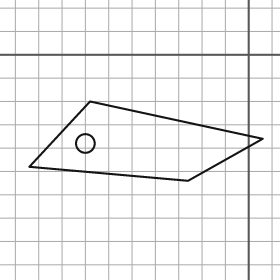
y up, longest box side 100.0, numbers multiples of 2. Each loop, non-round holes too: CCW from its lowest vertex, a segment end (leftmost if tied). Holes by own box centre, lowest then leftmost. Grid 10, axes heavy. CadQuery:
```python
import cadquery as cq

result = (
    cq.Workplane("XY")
    .moveTo(-26.0, -54.0)
    .lineTo(6.0, -36.0)
    .lineTo(-68.0, -20.0)
    .lineTo(-94.0, -48.0)
    .close()
    .moveTo(-70.0, -38.0)
    .circle(4.0)
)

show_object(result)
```